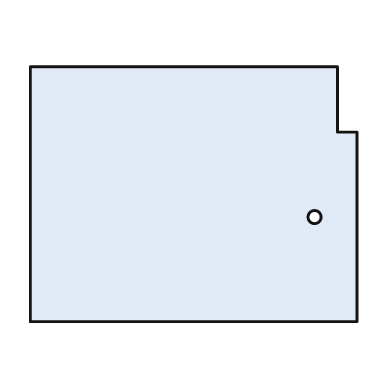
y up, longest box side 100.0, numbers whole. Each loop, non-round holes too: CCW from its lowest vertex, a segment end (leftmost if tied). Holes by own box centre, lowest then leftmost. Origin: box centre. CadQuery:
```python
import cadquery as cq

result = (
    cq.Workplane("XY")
    .moveTo(-50.0, -39.0)
    .lineTo(50.0, -39.0)
    .lineTo(50.0, 19.0)
    .lineTo(44.0, 19.0)
    .lineTo(44.0, 39.0)
    .lineTo(-50.0, 39.0)
    .close()
    .moveTo(37.0, -7.0)
    .circle(2.0)
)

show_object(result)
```